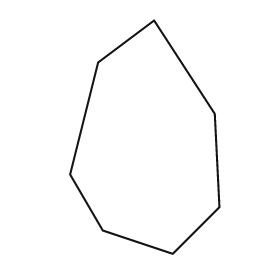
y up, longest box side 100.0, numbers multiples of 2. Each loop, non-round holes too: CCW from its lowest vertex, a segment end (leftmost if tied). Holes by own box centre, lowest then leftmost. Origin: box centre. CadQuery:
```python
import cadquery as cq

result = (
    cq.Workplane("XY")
    .moveTo(12.0, -50.0)
    .lineTo(32.0, -30.0)
    .lineTo(30.0, 10.0)
    .lineTo(4.0, 50.0)
    .lineTo(-20.0, 32.0)
    .lineTo(-32.0, -16.0)
    .lineTo(-18.0, -40.0)
    .close()
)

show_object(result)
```